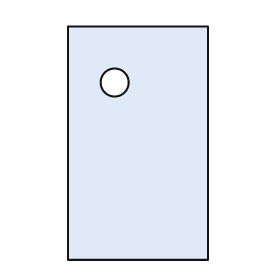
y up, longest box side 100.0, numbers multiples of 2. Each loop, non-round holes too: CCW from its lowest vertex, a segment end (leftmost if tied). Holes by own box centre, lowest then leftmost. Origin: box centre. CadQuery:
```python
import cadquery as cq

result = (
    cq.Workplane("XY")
    .moveTo(-30.0, -50.0)
    .lineTo(30.0, -50.0)
    .lineTo(30.0, 50.0)
    .lineTo(-30.0, 50.0)
    .close()
    .moveTo(-10.0, 26.0)
    .circle(6.0)
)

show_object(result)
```